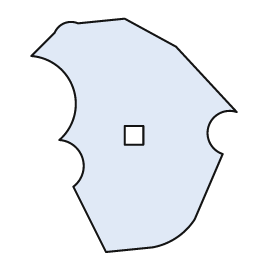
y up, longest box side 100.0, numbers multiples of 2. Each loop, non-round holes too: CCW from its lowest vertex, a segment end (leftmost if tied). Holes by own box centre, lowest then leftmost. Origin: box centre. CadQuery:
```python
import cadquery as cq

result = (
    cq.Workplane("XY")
    .moveTo(-12.0, -50.0)
    .lineTo(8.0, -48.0)
    .threePointArc((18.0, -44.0), (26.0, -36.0))
    .lineTo(38.0, -8.0)
    .threePointArc((32.0, 4.0), (44.0, 10.0))
    .lineTo(18.0, 38.0)
    .lineTo(-4.0, 50.0)
    .lineTo(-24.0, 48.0)
    .threePointArc((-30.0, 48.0), (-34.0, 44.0))
    .lineTo(-44.0, 34.0)
    .threePointArc((-26.0, 20.0), (-32.0, -2.0))
    .threePointArc((-22.0, -10.0), (-26.0, -22.0))
    .close()
    .moveTo(-4.0, -4.0)
    .lineTo(4.0, -4.0)
    .lineTo(4.0, 4.0)
    .lineTo(-4.0, 4.0)
    .close()
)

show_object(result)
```